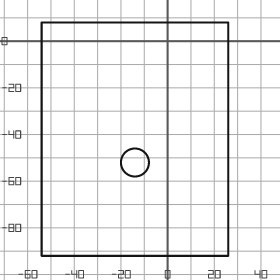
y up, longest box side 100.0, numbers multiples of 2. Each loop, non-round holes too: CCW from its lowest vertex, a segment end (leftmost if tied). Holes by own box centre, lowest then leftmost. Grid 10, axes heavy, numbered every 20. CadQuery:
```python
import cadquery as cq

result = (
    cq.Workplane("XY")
    .moveTo(-54.0, -92.0)
    .lineTo(26.0, -92.0)
    .lineTo(26.0, 8.0)
    .lineTo(-54.0, 8.0)
    .close()
    .moveTo(-14.0, -52.0)
    .circle(6.0)
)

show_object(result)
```